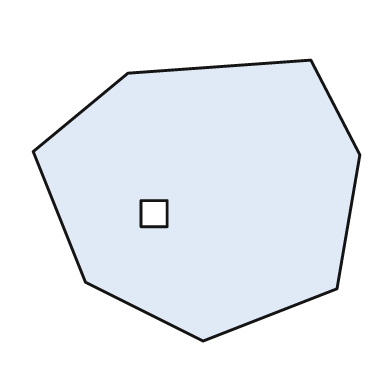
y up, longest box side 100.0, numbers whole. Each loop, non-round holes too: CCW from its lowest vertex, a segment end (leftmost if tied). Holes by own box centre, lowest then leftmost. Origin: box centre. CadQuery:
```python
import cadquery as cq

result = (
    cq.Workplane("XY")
    .moveTo(2.0, -43.0)
    .lineTo(43.0, -27.0)
    .lineTo(50.0, 14.0)
    .lineTo(35.0, 43.0)
    .lineTo(-21.0, 39.0)
    .lineTo(-50.0, 15.0)
    .lineTo(-34.0, -25.0)
    .close()
    .moveTo(-17.0, -8.0)
    .lineTo(-9.0, -8.0)
    .lineTo(-9.0, 0.0)
    .lineTo(-17.0, 0.0)
    .close()
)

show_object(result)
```